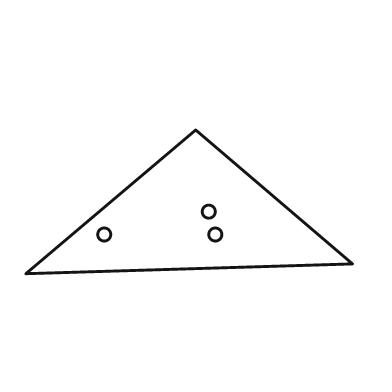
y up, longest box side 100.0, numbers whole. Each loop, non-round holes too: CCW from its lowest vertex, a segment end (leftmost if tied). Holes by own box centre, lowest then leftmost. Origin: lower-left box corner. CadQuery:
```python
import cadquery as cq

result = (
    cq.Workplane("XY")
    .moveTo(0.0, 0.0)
    .lineTo(100.0, 3.0)
    .lineTo(52.0, 44.0)
    .close()
    .moveTo(24.0, 12.0)
    .circle(2.0)
    .moveTo(58.0, 12.0)
    .circle(2.0)
    .moveTo(56.0, 19.0)
    .circle(2.0)
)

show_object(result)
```